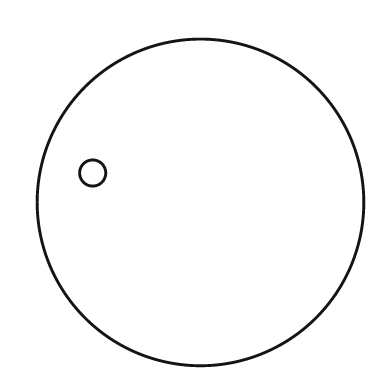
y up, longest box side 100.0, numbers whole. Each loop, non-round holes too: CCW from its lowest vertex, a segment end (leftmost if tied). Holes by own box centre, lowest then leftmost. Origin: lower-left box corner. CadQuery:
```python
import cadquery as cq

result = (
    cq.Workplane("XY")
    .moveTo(50.0, 50.0)
    .circle(50.0)
    .moveTo(17.0, 59.0)
    .circle(4.0)
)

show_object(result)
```